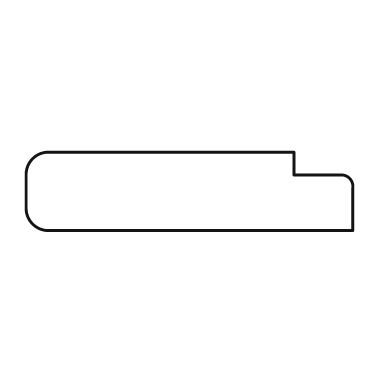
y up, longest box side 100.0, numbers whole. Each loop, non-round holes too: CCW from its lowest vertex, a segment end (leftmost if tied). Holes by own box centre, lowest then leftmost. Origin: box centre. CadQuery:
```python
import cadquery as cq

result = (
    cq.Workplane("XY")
    .moveTo(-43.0, -12.0)
    .lineTo(50.0, -12.0)
    .lineTo(50.0, 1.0)
    .threePointArc((49.0, 4.0), (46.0, 5.0))
    .lineTo(32.0, 5.0)
    .lineTo(32.0, 12.0)
    .lineTo(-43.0, 12.0)
    .threePointArc((-48.0, 10.0), (-50.0, 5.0))
    .lineTo(-50.0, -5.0)
    .threePointArc((-48.0, -10.0), (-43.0, -12.0))
    .close()
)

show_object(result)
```